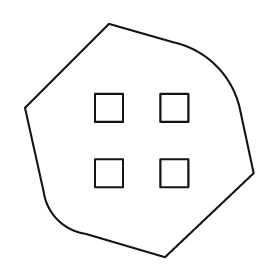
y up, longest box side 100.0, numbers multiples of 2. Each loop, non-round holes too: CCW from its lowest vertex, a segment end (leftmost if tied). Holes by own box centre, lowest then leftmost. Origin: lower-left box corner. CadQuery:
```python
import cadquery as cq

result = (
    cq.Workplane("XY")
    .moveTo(60.0, 0.0)
    .lineTo(98.0, 36.0)
    .lineTo(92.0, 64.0)
    .threePointArc((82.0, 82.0), (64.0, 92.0))
    .lineTo(36.0, 100.0)
    .lineTo(0.0, 64.0)
    .lineTo(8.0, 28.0)
    .threePointArc((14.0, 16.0), (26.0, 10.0))
    .close()
    .moveTo(30.0, 30.0)
    .lineTo(42.0, 30.0)
    .lineTo(42.0, 42.0)
    .lineTo(30.0, 42.0)
    .close()
    .moveTo(58.0, 30.0)
    .lineTo(70.0, 30.0)
    .lineTo(70.0, 42.0)
    .lineTo(58.0, 42.0)
    .close()
    .moveTo(30.0, 58.0)
    .lineTo(42.0, 58.0)
    .lineTo(42.0, 70.0)
    .lineTo(30.0, 70.0)
    .close()
    .moveTo(58.0, 58.0)
    .lineTo(70.0, 58.0)
    .lineTo(70.0, 70.0)
    .lineTo(58.0, 70.0)
    .close()
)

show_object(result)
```